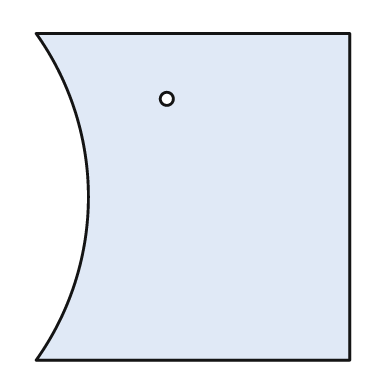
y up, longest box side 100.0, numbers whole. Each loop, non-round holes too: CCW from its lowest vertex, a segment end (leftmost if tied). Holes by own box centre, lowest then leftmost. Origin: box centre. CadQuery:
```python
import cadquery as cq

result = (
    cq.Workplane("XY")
    .moveTo(-48.0, -50.0)
    .lineTo(48.0, -50.0)
    .lineTo(48.0, 50.0)
    .lineTo(-48.0, 50.0)
    .threePointArc((-32.0, 0.0), (-48.0, -50.0))
    .close()
    .moveTo(-8.0, 30.0)
    .circle(2.0)
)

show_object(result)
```